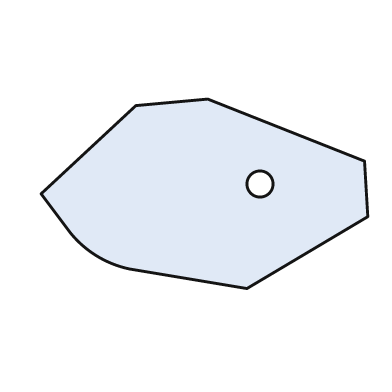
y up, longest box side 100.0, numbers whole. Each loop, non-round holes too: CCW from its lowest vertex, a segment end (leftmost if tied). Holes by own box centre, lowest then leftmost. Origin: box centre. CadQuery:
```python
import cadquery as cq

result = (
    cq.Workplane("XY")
    .moveTo(13.0, -29.0)
    .lineTo(50.0, -7.0)
    .lineTo(49.0, 10.0)
    .lineTo(1.0, 29.0)
    .lineTo(-21.0, 27.0)
    .lineTo(-50.0, 0.0)
    .lineTo(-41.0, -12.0)
    .threePointArc((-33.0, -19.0), (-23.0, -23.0))
    .close()
    .moveTo(17.0, 3.0)
    .circle(4.0)
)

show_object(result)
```